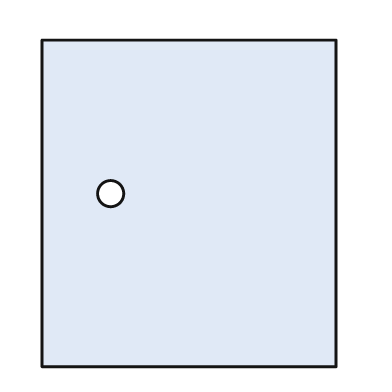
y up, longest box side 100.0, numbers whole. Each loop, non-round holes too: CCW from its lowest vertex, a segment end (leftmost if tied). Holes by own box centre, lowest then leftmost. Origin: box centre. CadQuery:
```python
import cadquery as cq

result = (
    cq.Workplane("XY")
    .moveTo(-45.0, -50.0)
    .lineTo(45.0, -50.0)
    .lineTo(45.0, 50.0)
    .lineTo(-45.0, 50.0)
    .close()
    .moveTo(-24.0, 3.0)
    .circle(4.0)
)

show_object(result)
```